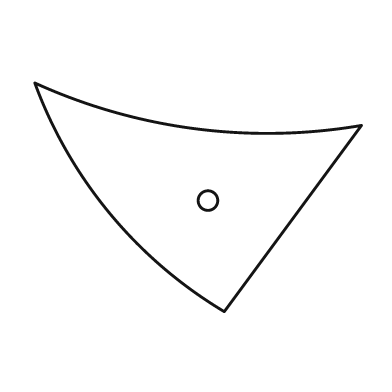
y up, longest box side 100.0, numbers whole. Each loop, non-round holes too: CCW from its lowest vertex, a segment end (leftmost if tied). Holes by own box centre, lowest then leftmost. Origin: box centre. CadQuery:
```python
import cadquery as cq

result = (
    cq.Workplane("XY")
    .moveTo(8.0, -35.0)
    .lineTo(50.0, 22.0)
    .threePointArc((-1.0, 21.0), (-50.0, 35.0))
    .threePointArc((-27.0, -5.0), (8.0, -35.0))
    .close()
    .moveTo(3.0, -1.0)
    .circle(3.0)
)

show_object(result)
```